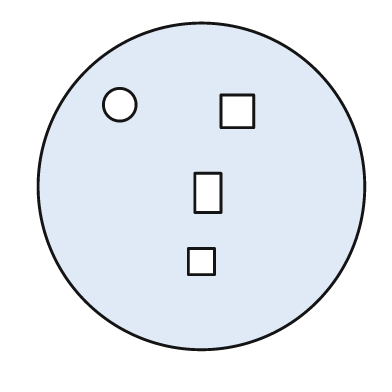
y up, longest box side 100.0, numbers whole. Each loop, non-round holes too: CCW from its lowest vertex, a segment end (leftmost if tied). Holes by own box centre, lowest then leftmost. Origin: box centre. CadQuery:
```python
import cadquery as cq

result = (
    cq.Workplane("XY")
    .moveTo(0.0, 0.0)
    .circle(50.0)
    .moveTo(-4.0, -27.0)
    .lineTo(4.0, -27.0)
    .lineTo(4.0, -19.0)
    .lineTo(-4.0, -19.0)
    .close()
    .moveTo(-2.0, -8.0)
    .lineTo(6.0, -8.0)
    .lineTo(6.0, 4.0)
    .lineTo(-2.0, 4.0)
    .close()
    .moveTo(6.0, 18.0)
    .lineTo(16.0, 18.0)
    .lineTo(16.0, 28.0)
    .lineTo(6.0, 28.0)
    .close()
    .moveTo(-25.0, 25.0)
    .circle(5.0)
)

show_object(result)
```